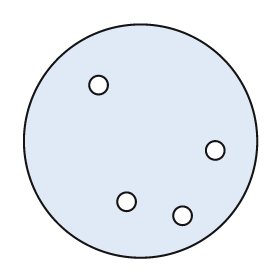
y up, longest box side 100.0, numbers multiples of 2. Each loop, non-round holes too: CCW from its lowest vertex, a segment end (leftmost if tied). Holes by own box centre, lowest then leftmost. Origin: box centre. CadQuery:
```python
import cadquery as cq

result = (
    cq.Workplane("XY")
    .moveTo(0.0, 0.0)
    .circle(50.0)
    .moveTo(18.0, -32.0)
    .circle(4.0)
    .moveTo(-6.0, -26.0)
    .circle(4.0)
    .moveTo(32.0, -4.0)
    .circle(4.0)
    .moveTo(-18.0, 24.0)
    .circle(4.0)
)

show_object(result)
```